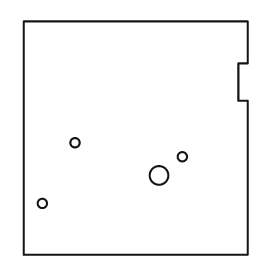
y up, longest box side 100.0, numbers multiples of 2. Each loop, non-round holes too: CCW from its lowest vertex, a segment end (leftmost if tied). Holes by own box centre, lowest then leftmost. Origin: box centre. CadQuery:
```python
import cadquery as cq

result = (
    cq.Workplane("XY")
    .moveTo(-48.0, -50.0)
    .lineTo(48.0, -50.0)
    .lineTo(48.0, 16.0)
    .lineTo(44.0, 16.0)
    .lineTo(44.0, 32.0)
    .lineTo(48.0, 32.0)
    .lineTo(48.0, 50.0)
    .lineTo(-48.0, 50.0)
    .close()
    .moveTo(-40.0, -28.0)
    .circle(2.0)
    .moveTo(10.0, -16.0)
    .circle(4.0)
    .moveTo(20.0, -8.0)
    .circle(2.0)
    .moveTo(-26.0, -2.0)
    .circle(2.0)
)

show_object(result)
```